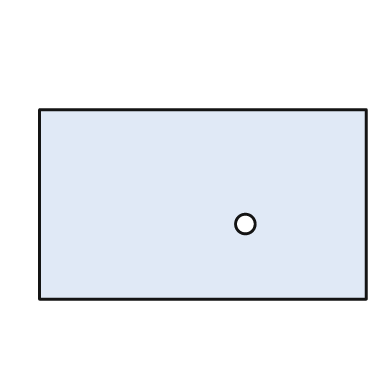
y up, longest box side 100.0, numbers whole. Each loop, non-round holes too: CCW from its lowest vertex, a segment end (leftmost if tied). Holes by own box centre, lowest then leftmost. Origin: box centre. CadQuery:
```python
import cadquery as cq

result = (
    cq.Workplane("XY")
    .moveTo(-50.0, -29.0)
    .lineTo(50.0, -29.0)
    .lineTo(50.0, 29.0)
    .lineTo(-50.0, 29.0)
    .close()
    .moveTo(13.0, -6.0)
    .circle(3.0)
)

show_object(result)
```